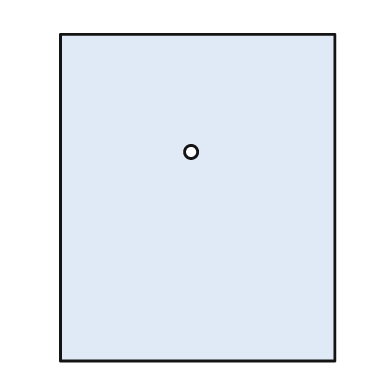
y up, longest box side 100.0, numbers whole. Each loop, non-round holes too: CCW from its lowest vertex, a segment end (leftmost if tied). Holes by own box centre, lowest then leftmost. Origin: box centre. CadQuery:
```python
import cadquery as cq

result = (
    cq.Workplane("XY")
    .moveTo(-42.0, -50.0)
    .lineTo(42.0, -50.0)
    .lineTo(42.0, 50.0)
    .lineTo(-42.0, 50.0)
    .close()
    .moveTo(-2.0, 14.0)
    .circle(2.0)
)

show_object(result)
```